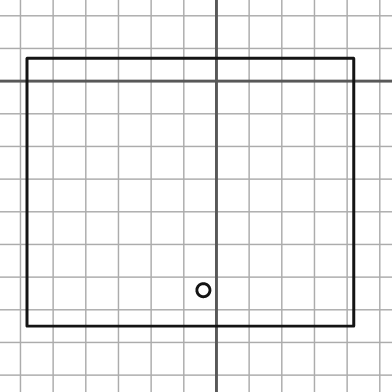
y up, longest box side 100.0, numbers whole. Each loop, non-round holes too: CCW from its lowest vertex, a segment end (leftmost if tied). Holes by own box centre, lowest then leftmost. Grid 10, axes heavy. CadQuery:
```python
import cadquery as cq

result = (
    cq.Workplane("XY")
    .moveTo(-58.0, -75.0)
    .lineTo(42.0, -75.0)
    .lineTo(42.0, 7.0)
    .lineTo(-58.0, 7.0)
    .close()
    .moveTo(-4.0, -64.0)
    .circle(2.0)
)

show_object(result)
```